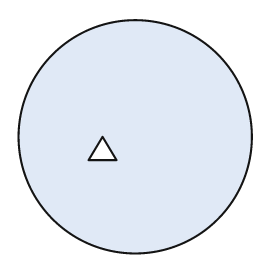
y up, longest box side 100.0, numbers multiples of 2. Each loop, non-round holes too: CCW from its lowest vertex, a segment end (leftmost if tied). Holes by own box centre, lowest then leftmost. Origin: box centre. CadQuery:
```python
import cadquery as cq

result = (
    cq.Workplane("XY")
    .moveTo(0.0, 0.0)
    .circle(50.0)
    .moveTo(-20.0, -10.0)
    .lineTo(-8.0, -10.0)
    .lineTo(-14.0, 0.0)
    .close()
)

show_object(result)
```